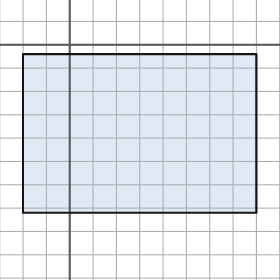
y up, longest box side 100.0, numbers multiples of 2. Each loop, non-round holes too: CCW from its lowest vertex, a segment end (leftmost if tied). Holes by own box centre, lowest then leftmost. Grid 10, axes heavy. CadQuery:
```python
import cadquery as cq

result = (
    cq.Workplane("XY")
    .moveTo(-20.0, -72.0)
    .lineTo(80.0, -72.0)
    .lineTo(80.0, -4.0)
    .lineTo(-20.0, -4.0)
    .close()
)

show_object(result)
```